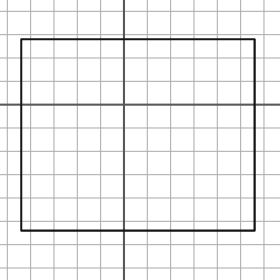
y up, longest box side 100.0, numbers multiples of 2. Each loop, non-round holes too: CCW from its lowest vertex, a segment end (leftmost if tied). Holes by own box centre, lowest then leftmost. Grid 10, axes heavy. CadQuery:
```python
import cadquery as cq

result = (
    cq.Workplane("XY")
    .moveTo(-44.0, -54.0)
    .lineTo(56.0, -54.0)
    .lineTo(56.0, 28.0)
    .lineTo(-44.0, 28.0)
    .close()
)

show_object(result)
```